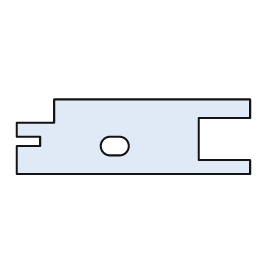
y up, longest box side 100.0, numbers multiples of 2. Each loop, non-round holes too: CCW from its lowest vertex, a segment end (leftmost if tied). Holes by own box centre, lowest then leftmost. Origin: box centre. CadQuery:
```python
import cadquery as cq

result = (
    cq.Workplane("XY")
    .moveTo(-50.0, -16.0)
    .lineTo(50.0, -16.0)
    .lineTo(50.0, -10.0)
    .lineTo(28.0, -10.0)
    .lineTo(28.0, 8.0)
    .lineTo(50.0, 8.0)
    .lineTo(50.0, 16.0)
    .lineTo(-34.0, 16.0)
    .lineTo(-34.0, 6.0)
    .lineTo(-50.0, 6.0)
    .lineTo(-50.0, 0.0)
    .lineTo(-40.0, 0.0)
    .lineTo(-40.0, -4.0)
    .lineTo(-50.0, -4.0)
    .close()
    .moveTo(-10.0, -8.0)
    .lineTo(-6.0, -8.0)
    .threePointArc((-2.0, -4.0), (-6.0, 0.0))
    .lineTo(-10.0, 0.0)
    .threePointArc((-14.0, -4.0), (-10.0, -8.0))
    .close()
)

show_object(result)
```